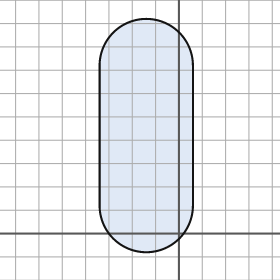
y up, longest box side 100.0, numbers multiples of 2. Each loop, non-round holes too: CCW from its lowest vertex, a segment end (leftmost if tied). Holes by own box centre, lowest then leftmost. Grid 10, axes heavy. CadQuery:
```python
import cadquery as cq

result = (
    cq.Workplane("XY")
    .moveTo(-34.0, 12.0)
    .threePointArc((-14.0, -8.0), (6.0, 12.0))
    .lineTo(6.0, 72.0)
    .threePointArc((-14.0, 92.0), (-34.0, 72.0))
    .close()
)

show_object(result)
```